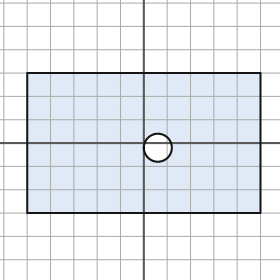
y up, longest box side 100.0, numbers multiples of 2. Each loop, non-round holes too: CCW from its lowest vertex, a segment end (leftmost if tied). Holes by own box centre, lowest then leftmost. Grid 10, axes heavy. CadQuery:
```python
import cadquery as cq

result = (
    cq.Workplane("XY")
    .moveTo(-50.0, -30.0)
    .lineTo(50.0, -30.0)
    .lineTo(50.0, 30.0)
    .lineTo(-50.0, 30.0)
    .close()
    .moveTo(6.0, -2.0)
    .circle(6.0)
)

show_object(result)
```